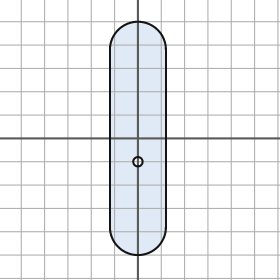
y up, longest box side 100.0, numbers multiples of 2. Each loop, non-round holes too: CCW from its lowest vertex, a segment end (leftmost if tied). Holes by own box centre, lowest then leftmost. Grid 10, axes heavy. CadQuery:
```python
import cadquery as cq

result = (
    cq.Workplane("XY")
    .moveTo(-12.0, -38.0)
    .threePointArc((0.0, -50.0), (12.0, -38.0))
    .lineTo(12.0, 38.0)
    .threePointArc((0.0, 50.0), (-12.0, 38.0))
    .close()
    .moveTo(0.0, -10.0)
    .circle(2.0)
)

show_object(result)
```